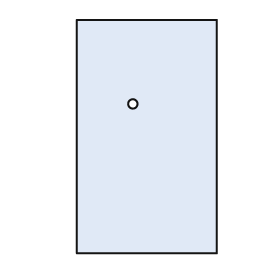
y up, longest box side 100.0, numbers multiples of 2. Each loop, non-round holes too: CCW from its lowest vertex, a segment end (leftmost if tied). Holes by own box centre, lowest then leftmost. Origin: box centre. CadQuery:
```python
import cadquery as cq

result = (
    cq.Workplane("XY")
    .moveTo(-30.0, -50.0)
    .lineTo(30.0, -50.0)
    .lineTo(30.0, 50.0)
    .lineTo(-30.0, 50.0)
    .close()
    .moveTo(-6.0, 14.0)
    .circle(2.0)
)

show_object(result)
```